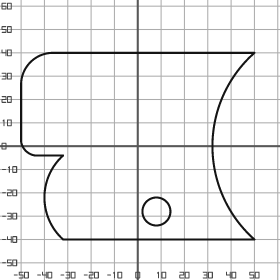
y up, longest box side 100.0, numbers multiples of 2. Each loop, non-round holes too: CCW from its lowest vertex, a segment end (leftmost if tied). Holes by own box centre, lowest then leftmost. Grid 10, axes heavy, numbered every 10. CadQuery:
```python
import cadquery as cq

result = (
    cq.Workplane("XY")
    .moveTo(-32.0, -40.0)
    .lineTo(50.0, -40.0)
    .threePointArc((32.0, 0.0), (50.0, 40.0))
    .lineTo(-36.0, 40.0)
    .threePointArc((-46.0, 36.0), (-50.0, 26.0))
    .lineTo(-50.0, 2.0)
    .threePointArc((-48.0, -2.0), (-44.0, -4.0))
    .lineTo(-32.0, -4.0)
    .threePointArc((-40.0, -22.0), (-32.0, -40.0))
    .close()
    .moveTo(8.0, -28.0)
    .circle(6.0)
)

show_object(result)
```